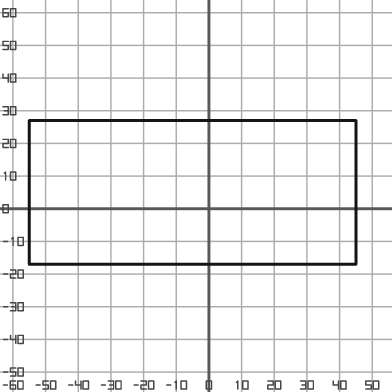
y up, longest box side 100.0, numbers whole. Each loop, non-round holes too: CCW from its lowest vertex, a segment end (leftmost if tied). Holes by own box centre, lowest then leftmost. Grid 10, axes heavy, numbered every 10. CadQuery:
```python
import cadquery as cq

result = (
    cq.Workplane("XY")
    .moveTo(-55.0, -17.0)
    .lineTo(45.0, -17.0)
    .lineTo(45.0, 27.0)
    .lineTo(-55.0, 27.0)
    .close()
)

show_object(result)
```